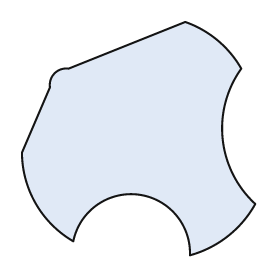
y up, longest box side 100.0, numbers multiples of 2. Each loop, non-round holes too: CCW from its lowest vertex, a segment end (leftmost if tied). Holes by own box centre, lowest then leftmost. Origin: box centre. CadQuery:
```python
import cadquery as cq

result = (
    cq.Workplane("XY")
    .moveTo(22.0, -50.0)
    .threePointArc((38.0, -42.0), (50.0, -28.0))
    .threePointArc((36.0, 0.0), (44.0, 30.0))
    .threePointArc((34.0, 42.0), (20.0, 50.0))
    .lineTo(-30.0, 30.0)
    .threePointArc((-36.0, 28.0), (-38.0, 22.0))
    .lineTo(-50.0, -6.0)
    .threePointArc((-44.0, -28.0), (-28.0, -44.0))
    .threePointArc((0.0, -24.0), (22.0, -50.0))
    .close()
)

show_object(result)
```